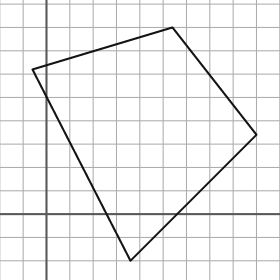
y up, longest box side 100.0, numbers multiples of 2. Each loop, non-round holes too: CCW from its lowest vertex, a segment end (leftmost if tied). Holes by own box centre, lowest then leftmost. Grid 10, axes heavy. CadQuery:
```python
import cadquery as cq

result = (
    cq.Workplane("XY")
    .moveTo(36.0, -20.0)
    .lineTo(90.0, 34.0)
    .lineTo(54.0, 80.0)
    .lineTo(-6.0, 62.0)
    .close()
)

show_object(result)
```